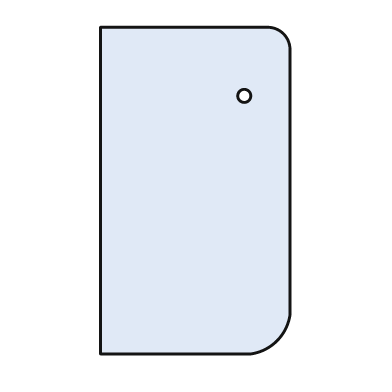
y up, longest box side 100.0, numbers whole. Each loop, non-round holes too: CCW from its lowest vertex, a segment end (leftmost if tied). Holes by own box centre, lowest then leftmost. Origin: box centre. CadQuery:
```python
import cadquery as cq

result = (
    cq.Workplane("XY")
    .moveTo(-29.0, -50.0)
    .lineTo(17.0, -50.0)
    .threePointArc((25.0, -46.0), (29.0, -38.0))
    .lineTo(29.0, 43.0)
    .threePointArc((27.0, 48.0), (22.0, 50.0))
    .lineTo(-29.0, 50.0)
    .close()
    .moveTo(15.0, 29.0)
    .circle(2.0)
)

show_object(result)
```